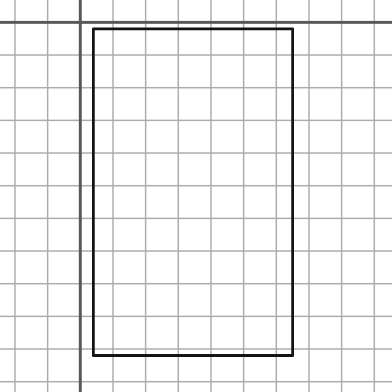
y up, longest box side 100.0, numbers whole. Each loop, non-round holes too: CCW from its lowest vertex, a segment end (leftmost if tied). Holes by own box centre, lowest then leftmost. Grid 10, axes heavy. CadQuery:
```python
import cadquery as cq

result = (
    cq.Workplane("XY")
    .moveTo(4.0, -102.0)
    .lineTo(65.0, -102.0)
    .lineTo(65.0, -2.0)
    .lineTo(4.0, -2.0)
    .close()
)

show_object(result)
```